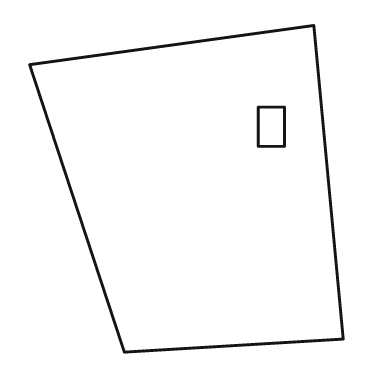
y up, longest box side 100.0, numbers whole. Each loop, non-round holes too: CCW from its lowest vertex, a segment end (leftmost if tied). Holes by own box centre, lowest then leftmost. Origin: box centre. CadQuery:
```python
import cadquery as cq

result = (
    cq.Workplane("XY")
    .moveTo(-19.0, -50.0)
    .lineTo(48.0, -46.0)
    .lineTo(39.0, 50.0)
    .lineTo(-48.0, 38.0)
    .close()
    .moveTo(22.0, 13.0)
    .lineTo(30.0, 13.0)
    .lineTo(30.0, 25.0)
    .lineTo(22.0, 25.0)
    .close()
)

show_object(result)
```